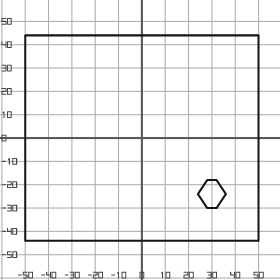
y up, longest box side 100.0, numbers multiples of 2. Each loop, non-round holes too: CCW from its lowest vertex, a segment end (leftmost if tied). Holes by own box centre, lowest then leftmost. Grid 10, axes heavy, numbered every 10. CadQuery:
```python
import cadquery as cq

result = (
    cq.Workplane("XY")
    .moveTo(-50.0, -44.0)
    .lineTo(50.0, -44.0)
    .lineTo(50.0, 44.0)
    .lineTo(-50.0, 44.0)
    .close()
    .moveTo(28.0, -30.0)
    .lineTo(32.0, -30.0)
    .lineTo(36.0, -24.0)
    .lineTo(32.0, -18.0)
    .lineTo(28.0, -18.0)
    .lineTo(24.0, -24.0)
    .close()
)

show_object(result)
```